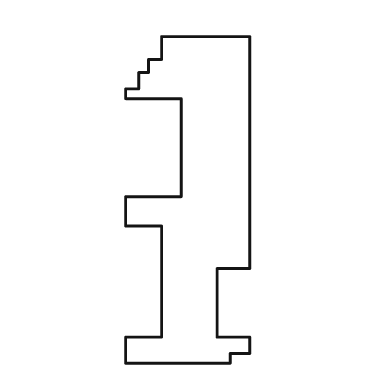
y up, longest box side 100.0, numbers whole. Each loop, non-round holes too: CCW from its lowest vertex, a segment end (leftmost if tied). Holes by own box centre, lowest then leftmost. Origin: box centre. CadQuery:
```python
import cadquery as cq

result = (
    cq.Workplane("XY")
    .moveTo(-19.0, -50.0)
    .lineTo(13.0, -50.0)
    .lineTo(13.0, -47.0)
    .lineTo(19.0, -47.0)
    .lineTo(19.0, -42.0)
    .lineTo(9.0, -42.0)
    .lineTo(9.0, -21.0)
    .lineTo(19.0, -21.0)
    .lineTo(19.0, 50.0)
    .lineTo(-8.0, 50.0)
    .lineTo(-8.0, 43.0)
    .lineTo(-12.0, 43.0)
    .lineTo(-12.0, 39.0)
    .lineTo(-15.0, 39.0)
    .lineTo(-15.0, 34.0)
    .lineTo(-19.0, 34.0)
    .lineTo(-19.0, 31.0)
    .lineTo(-2.0, 31.0)
    .lineTo(-2.0, 1.0)
    .lineTo(-19.0, 1.0)
    .lineTo(-19.0, -8.0)
    .lineTo(-8.0, -8.0)
    .lineTo(-8.0, -42.0)
    .lineTo(-19.0, -42.0)
    .close()
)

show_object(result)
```